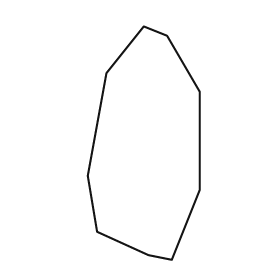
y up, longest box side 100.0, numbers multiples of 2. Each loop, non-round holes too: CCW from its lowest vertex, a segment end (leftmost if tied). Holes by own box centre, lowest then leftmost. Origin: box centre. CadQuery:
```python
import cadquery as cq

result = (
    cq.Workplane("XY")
    .moveTo(12.0, -50.0)
    .lineTo(24.0, -20.0)
    .lineTo(24.0, 22.0)
    .lineTo(10.0, 46.0)
    .lineTo(0.0, 50.0)
    .lineTo(-16.0, 30.0)
    .lineTo(-24.0, -14.0)
    .lineTo(-20.0, -38.0)
    .lineTo(2.0, -48.0)
    .close()
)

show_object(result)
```